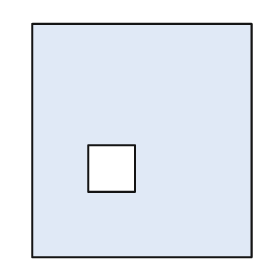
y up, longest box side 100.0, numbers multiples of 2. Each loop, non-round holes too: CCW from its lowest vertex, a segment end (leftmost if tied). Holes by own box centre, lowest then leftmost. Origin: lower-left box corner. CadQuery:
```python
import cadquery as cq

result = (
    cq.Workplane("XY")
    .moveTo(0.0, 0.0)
    .lineTo(94.0, 0.0)
    .lineTo(94.0, 100.0)
    .lineTo(0.0, 100.0)
    .close()
    .moveTo(24.0, 28.0)
    .lineTo(44.0, 28.0)
    .lineTo(44.0, 48.0)
    .lineTo(24.0, 48.0)
    .close()
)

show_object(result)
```